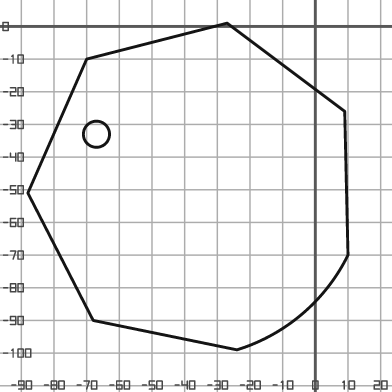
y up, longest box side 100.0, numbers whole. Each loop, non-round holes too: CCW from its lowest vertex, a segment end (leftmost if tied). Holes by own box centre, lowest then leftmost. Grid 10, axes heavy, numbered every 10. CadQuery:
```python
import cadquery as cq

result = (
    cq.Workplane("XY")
    .moveTo(-24.0, -99.0)
    .threePointArc((-4.0, -88.0), (10.0, -70.0))
    .lineTo(9.0, -26.0)
    .lineTo(-27.0, 1.0)
    .lineTo(-70.0, -10.0)
    .lineTo(-88.0, -51.0)
    .lineTo(-68.0, -90.0)
    .close()
    .moveTo(-67.0, -33.0)
    .circle(4.0)
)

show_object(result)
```